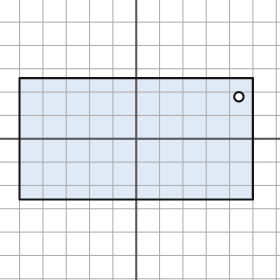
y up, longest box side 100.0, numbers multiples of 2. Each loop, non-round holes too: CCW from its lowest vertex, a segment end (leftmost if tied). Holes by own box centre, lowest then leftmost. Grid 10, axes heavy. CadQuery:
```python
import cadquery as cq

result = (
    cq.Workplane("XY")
    .moveTo(-50.0, -26.0)
    .lineTo(50.0, -26.0)
    .lineTo(50.0, 26.0)
    .lineTo(-50.0, 26.0)
    .close()
    .moveTo(44.0, 18.0)
    .circle(2.0)
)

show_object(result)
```